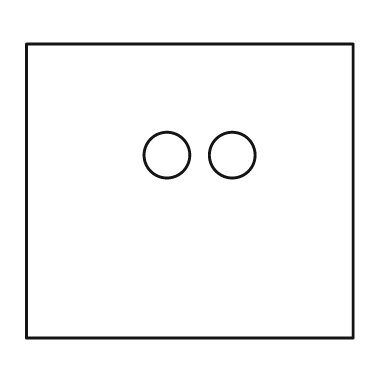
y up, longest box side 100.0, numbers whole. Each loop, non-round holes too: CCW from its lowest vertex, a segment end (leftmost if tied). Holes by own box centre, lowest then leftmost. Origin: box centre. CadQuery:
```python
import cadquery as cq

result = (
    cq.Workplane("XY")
    .moveTo(-50.0, -45.0)
    .lineTo(50.0, -45.0)
    .lineTo(50.0, 45.0)
    .lineTo(-50.0, 45.0)
    .close()
    .moveTo(-7.0, 11.0)
    .circle(7.0)
    .moveTo(13.0, 11.0)
    .circle(7.0)
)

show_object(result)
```